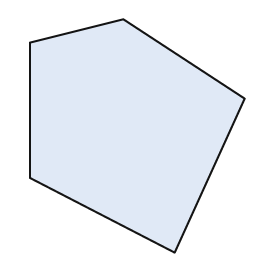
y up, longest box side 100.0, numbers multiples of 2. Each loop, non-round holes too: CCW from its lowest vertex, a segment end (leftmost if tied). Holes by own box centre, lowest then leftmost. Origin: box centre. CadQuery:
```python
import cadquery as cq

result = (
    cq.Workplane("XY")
    .moveTo(16.0, -50.0)
    .lineTo(46.0, 16.0)
    .lineTo(-6.0, 50.0)
    .lineTo(-46.0, 40.0)
    .lineTo(-46.0, -18.0)
    .close()
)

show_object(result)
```